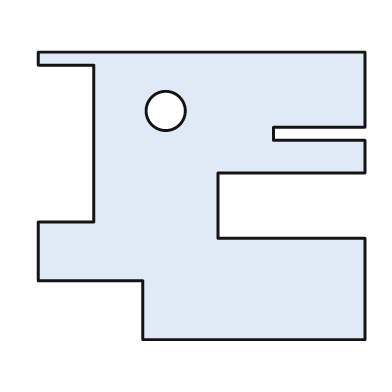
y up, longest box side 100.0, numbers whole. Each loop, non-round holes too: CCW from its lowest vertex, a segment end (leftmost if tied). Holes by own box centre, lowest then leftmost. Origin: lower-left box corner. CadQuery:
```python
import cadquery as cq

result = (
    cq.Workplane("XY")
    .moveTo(32.0, 0.0)
    .lineTo(100.0, 0.0)
    .lineTo(100.0, 31.0)
    .lineTo(55.0, 31.0)
    .lineTo(55.0, 51.0)
    .lineTo(100.0, 51.0)
    .lineTo(100.0, 61.0)
    .lineTo(72.0, 61.0)
    .lineTo(72.0, 65.0)
    .lineTo(100.0, 65.0)
    .lineTo(100.0, 88.0)
    .lineTo(0.0, 88.0)
    .lineTo(0.0, 84.0)
    .lineTo(17.0, 84.0)
    .lineTo(17.0, 36.0)
    .lineTo(0.0, 36.0)
    .lineTo(0.0, 18.0)
    .lineTo(32.0, 18.0)
    .close()
    .moveTo(39.0, 70.0)
    .circle(6.0)
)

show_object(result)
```